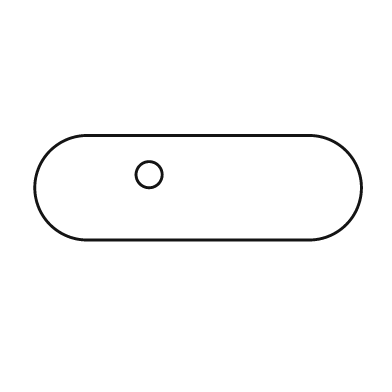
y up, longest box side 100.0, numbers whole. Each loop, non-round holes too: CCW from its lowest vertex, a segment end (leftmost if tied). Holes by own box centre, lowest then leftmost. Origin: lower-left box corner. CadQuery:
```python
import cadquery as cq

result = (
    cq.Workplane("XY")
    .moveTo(16.0, 0.0)
    .lineTo(84.0, 0.0)
    .threePointArc((100.0, 16.0), (84.0, 32.0))
    .lineTo(16.0, 32.0)
    .threePointArc((0.0, 16.0), (16.0, 0.0))
    .close()
    .moveTo(35.0, 20.0)
    .circle(4.0)
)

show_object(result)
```